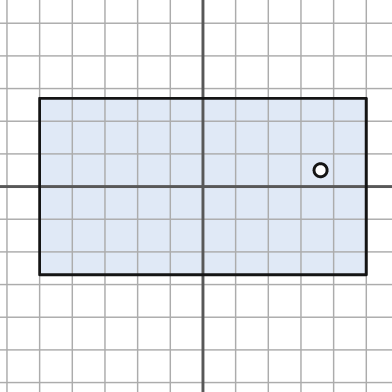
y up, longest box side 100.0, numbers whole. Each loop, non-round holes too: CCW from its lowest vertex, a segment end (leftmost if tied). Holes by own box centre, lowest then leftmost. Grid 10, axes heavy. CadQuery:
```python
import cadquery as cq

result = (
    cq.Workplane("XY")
    .moveTo(-50.0, -27.0)
    .lineTo(50.0, -27.0)
    .lineTo(50.0, 27.0)
    .lineTo(-50.0, 27.0)
    .close()
    .moveTo(36.0, 5.0)
    .circle(2.0)
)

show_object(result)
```